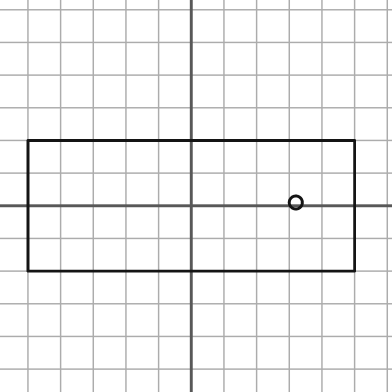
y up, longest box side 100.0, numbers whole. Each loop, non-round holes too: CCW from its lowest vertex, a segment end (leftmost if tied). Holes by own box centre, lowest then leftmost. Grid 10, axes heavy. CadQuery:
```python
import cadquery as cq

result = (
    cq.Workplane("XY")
    .moveTo(-50.0, -20.0)
    .lineTo(50.0, -20.0)
    .lineTo(50.0, 20.0)
    .lineTo(-50.0, 20.0)
    .close()
    .moveTo(32.0, 1.0)
    .circle(2.0)
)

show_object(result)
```